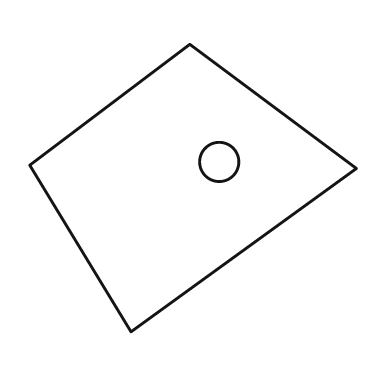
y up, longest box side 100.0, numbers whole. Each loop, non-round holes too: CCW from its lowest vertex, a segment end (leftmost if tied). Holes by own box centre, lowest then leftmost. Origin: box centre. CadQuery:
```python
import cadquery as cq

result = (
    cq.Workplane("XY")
    .moveTo(-19.0, -44.0)
    .lineTo(50.0, 6.0)
    .lineTo(-1.0, 44.0)
    .lineTo(-50.0, 7.0)
    .close()
    .moveTo(8.0, 8.0)
    .circle(6.0)
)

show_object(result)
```